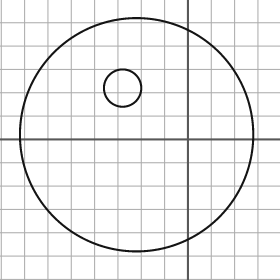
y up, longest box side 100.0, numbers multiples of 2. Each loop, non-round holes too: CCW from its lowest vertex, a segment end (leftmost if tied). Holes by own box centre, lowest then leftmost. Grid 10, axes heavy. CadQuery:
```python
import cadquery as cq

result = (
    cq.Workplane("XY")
    .moveTo(-22.0, 2.0)
    .circle(50.0)
    .moveTo(-28.0, 22.0)
    .circle(8.0)
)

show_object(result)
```